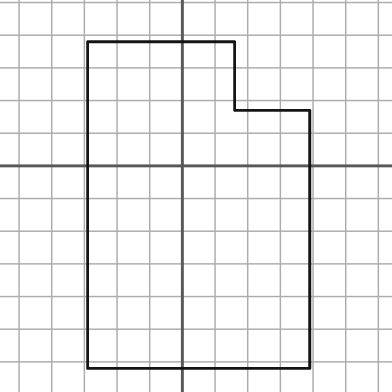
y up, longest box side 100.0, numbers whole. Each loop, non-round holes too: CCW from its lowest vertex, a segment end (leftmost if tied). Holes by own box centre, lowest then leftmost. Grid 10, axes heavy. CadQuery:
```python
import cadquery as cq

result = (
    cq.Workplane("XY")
    .moveTo(-29.0, -62.0)
    .lineTo(39.0, -62.0)
    .lineTo(39.0, 17.0)
    .lineTo(16.0, 17.0)
    .lineTo(16.0, 38.0)
    .lineTo(-29.0, 38.0)
    .close()
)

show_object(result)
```